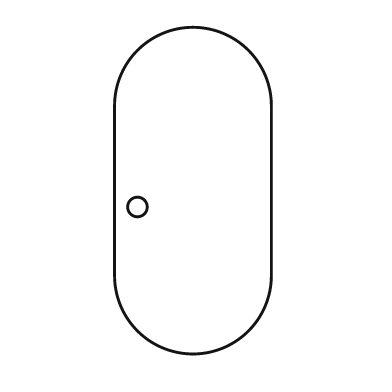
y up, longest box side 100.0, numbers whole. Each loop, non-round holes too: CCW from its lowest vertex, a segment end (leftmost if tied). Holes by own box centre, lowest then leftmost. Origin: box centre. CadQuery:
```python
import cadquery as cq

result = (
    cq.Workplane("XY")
    .moveTo(-24.0, -26.0)
    .threePointArc((0.0, -50.0), (24.0, -26.0))
    .lineTo(24.0, 26.0)
    .threePointArc((0.0, 50.0), (-24.0, 26.0))
    .close()
    .moveTo(-17.0, -5.0)
    .circle(3.0)
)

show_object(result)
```